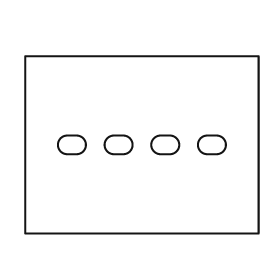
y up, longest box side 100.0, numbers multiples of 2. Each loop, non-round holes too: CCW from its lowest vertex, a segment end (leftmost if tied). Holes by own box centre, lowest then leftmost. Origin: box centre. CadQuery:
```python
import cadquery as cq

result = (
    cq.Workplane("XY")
    .moveTo(-50.0, -38.0)
    .lineTo(50.0, -38.0)
    .lineTo(50.0, 38.0)
    .lineTo(-50.0, 38.0)
    .close()
    .moveTo(-32.0, -4.0)
    .lineTo(-28.0, -4.0)
    .threePointArc((-24.0, 0.0), (-28.0, 4.0))
    .lineTo(-32.0, 4.0)
    .threePointArc((-36.0, 0.0), (-32.0, -4.0))
    .close()
    .moveTo(-12.0, -4.0)
    .lineTo(-8.0, -4.0)
    .threePointArc((-4.0, 0.0), (-8.0, 4.0))
    .lineTo(-12.0, 4.0)
    .threePointArc((-16.0, 0.0), (-12.0, -4.0))
    .close()
    .moveTo(8.0, -4.0)
    .lineTo(12.0, -4.0)
    .threePointArc((16.0, 0.0), (12.0, 4.0))
    .lineTo(8.0, 4.0)
    .threePointArc((4.0, 0.0), (8.0, -4.0))
    .close()
    .moveTo(28.0, -4.0)
    .lineTo(32.0, -4.0)
    .threePointArc((36.0, 0.0), (32.0, 4.0))
    .lineTo(28.0, 4.0)
    .threePointArc((24.0, 0.0), (28.0, -4.0))
    .close()
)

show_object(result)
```